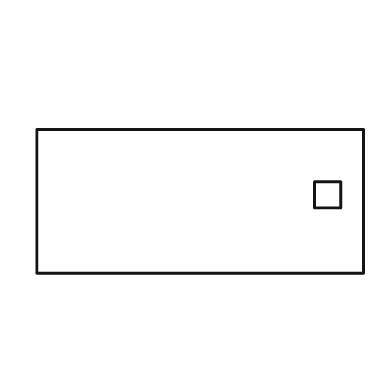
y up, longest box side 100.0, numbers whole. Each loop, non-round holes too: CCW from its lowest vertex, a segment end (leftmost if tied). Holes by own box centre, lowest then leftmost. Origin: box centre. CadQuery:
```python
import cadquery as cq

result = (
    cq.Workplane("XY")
    .moveTo(-50.0, -22.0)
    .lineTo(50.0, -22.0)
    .lineTo(50.0, 22.0)
    .lineTo(-50.0, 22.0)
    .close()
    .moveTo(35.0, -2.0)
    .lineTo(43.0, -2.0)
    .lineTo(43.0, 6.0)
    .lineTo(35.0, 6.0)
    .close()
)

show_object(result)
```